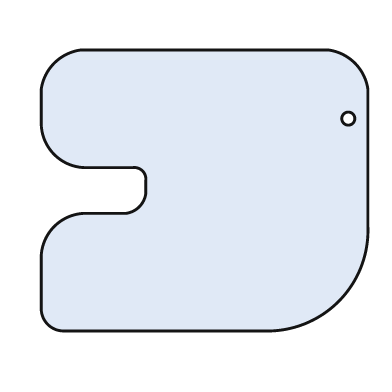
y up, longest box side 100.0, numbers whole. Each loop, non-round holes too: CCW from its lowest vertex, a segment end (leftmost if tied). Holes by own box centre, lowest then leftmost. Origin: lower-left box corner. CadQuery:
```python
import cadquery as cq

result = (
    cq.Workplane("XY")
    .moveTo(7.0, 0.0)
    .lineTo(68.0, 0.0)
    .threePointArc((91.0, 9.0), (100.0, 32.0))
    .lineTo(100.0, 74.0)
    .threePointArc((96.0, 82.0), (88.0, 86.0))
    .lineTo(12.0, 86.0)
    .threePointArc((4.0, 82.0), (0.0, 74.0))
    .lineTo(0.0, 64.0)
    .threePointArc((4.0, 54.0), (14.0, 50.0))
    .lineTo(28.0, 50.0)
    .threePointArc((31.0, 49.0), (32.0, 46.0))
    .lineTo(32.0, 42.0)
    .threePointArc((30.0, 38.0), (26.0, 36.0))
    .lineTo(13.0, 36.0)
    .threePointArc((4.0, 32.0), (0.0, 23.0))
    .lineTo(0.0, 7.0)
    .threePointArc((2.0, 2.0), (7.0, 0.0))
    .close()
    .moveTo(94.0, 65.0)
    .circle(2.0)
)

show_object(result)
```